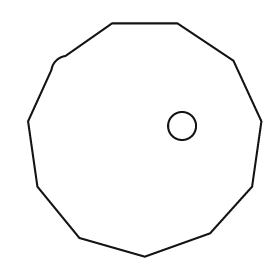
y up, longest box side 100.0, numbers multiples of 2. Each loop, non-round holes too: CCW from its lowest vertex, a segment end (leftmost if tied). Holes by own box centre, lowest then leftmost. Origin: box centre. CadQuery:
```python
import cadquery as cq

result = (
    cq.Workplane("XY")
    .moveTo(0.0, -50.0)
    .lineTo(28.0, -40.0)
    .lineTo(46.0, -20.0)
    .lineTo(50.0, 8.0)
    .lineTo(38.0, 34.0)
    .lineTo(14.0, 50.0)
    .lineTo(-14.0, 50.0)
    .lineTo(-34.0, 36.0)
    .threePointArc((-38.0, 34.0), (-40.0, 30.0))
    .lineTo(-50.0, 8.0)
    .lineTo(-46.0, -20.0)
    .lineTo(-28.0, -42.0)
    .close()
    .moveTo(16.0, 6.0)
    .circle(6.0)
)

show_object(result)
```